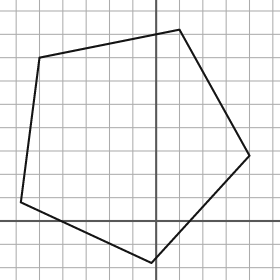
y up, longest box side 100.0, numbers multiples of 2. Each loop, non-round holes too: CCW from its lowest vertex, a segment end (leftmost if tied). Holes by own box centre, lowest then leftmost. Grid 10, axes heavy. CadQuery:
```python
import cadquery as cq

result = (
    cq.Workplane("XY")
    .moveTo(-2.0, -18.0)
    .lineTo(40.0, 28.0)
    .lineTo(10.0, 82.0)
    .lineTo(-50.0, 70.0)
    .lineTo(-58.0, 8.0)
    .close()
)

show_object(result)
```